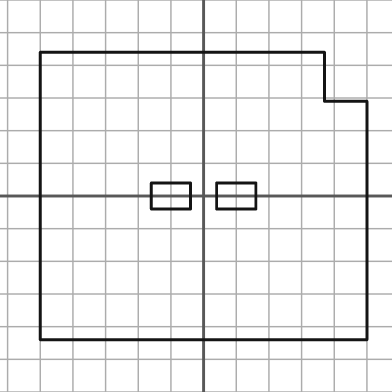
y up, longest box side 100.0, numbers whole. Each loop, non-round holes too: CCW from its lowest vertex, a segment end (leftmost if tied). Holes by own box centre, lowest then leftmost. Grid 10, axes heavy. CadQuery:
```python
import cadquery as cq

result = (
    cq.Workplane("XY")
    .moveTo(-50.0, -44.0)
    .lineTo(50.0, -44.0)
    .lineTo(50.0, 29.0)
    .lineTo(37.0, 29.0)
    .lineTo(37.0, 44.0)
    .lineTo(-50.0, 44.0)
    .close()
    .moveTo(-16.0, -4.0)
    .lineTo(-4.0, -4.0)
    .lineTo(-4.0, 4.0)
    .lineTo(-16.0, 4.0)
    .close()
    .moveTo(4.0, -4.0)
    .lineTo(16.0, -4.0)
    .lineTo(16.0, 4.0)
    .lineTo(4.0, 4.0)
    .close()
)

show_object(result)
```